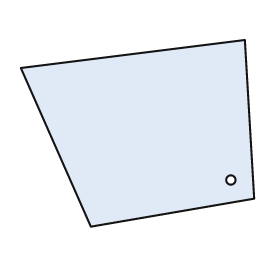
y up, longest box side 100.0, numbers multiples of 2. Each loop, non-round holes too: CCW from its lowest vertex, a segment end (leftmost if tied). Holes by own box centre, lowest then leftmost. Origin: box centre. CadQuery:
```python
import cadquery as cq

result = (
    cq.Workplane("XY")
    .moveTo(-20.0, -40.0)
    .lineTo(50.0, -28.0)
    .lineTo(46.0, 40.0)
    .lineTo(-50.0, 28.0)
    .close()
    .moveTo(40.0, -20.0)
    .circle(2.0)
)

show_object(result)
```